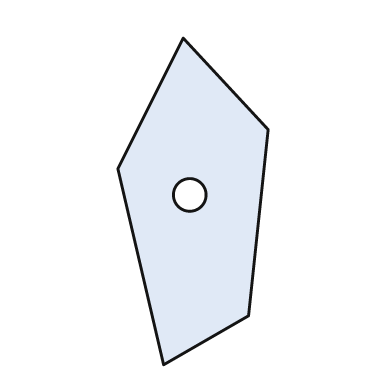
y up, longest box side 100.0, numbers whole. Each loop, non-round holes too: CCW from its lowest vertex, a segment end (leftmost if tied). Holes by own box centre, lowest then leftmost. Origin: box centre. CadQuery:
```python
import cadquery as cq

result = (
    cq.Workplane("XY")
    .moveTo(-9.0, -50.0)
    .lineTo(17.0, -35.0)
    .lineTo(23.0, 22.0)
    .lineTo(-3.0, 50.0)
    .lineTo(-23.0, 10.0)
    .close()
    .moveTo(-1.0, 2.0)
    .circle(5.0)
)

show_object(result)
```